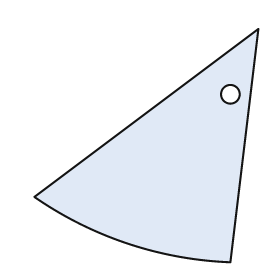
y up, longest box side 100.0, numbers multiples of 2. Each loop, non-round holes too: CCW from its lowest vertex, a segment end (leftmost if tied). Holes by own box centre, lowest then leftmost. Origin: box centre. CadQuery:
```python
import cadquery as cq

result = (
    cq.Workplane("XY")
    .moveTo(36.0, -50.0)
    .lineTo(48.0, 50.0)
    .lineTo(-48.0, -22.0)
    .threePointArc((-8.0, -42.0), (36.0, -50.0))
    .close()
    .moveTo(36.0, 22.0)
    .circle(4.0)
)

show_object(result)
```